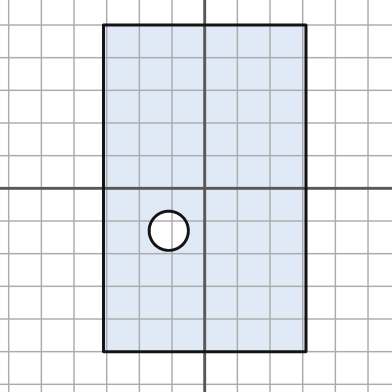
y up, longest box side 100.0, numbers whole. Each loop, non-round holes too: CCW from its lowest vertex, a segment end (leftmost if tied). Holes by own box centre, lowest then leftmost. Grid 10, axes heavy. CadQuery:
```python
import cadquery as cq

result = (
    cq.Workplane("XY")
    .moveTo(-31.0, -50.0)
    .lineTo(31.0, -50.0)
    .lineTo(31.0, 50.0)
    .lineTo(-31.0, 50.0)
    .close()
    .moveTo(-11.0, -13.0)
    .circle(6.0)
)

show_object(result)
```